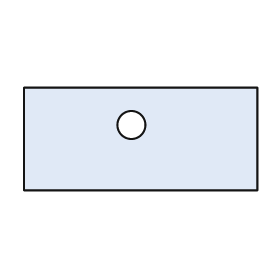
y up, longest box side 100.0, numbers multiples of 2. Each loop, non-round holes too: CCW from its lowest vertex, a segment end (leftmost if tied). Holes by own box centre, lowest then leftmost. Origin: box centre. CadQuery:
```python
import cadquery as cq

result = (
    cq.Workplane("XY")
    .moveTo(-50.0, -22.0)
    .lineTo(50.0, -22.0)
    .lineTo(50.0, 22.0)
    .lineTo(-50.0, 22.0)
    .close()
    .moveTo(-4.0, 6.0)
    .circle(6.0)
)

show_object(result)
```